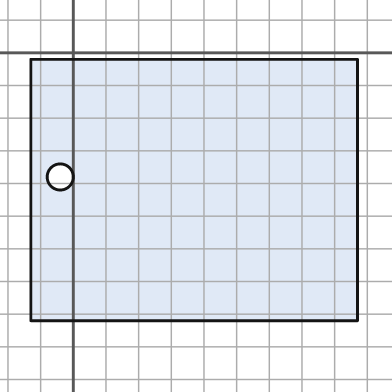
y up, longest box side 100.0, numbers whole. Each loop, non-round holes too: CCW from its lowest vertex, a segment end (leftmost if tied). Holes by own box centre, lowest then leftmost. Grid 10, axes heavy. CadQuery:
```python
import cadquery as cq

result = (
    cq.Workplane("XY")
    .moveTo(-13.0, -82.0)
    .lineTo(87.0, -82.0)
    .lineTo(87.0, -2.0)
    .lineTo(-13.0, -2.0)
    .close()
    .moveTo(-4.0, -38.0)
    .circle(4.0)
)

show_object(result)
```